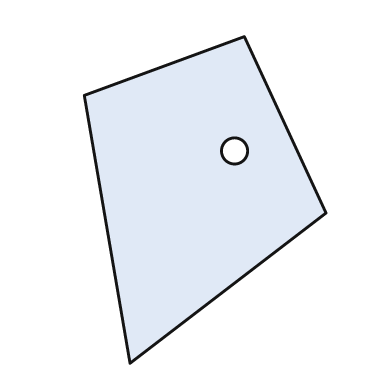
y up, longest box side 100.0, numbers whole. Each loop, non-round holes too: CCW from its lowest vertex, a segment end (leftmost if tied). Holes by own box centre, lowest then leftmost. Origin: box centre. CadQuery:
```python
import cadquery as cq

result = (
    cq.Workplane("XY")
    .moveTo(-23.0, -50.0)
    .lineTo(37.0, -4.0)
    .lineTo(12.0, 50.0)
    .lineTo(-37.0, 32.0)
    .close()
    .moveTo(9.0, 15.0)
    .circle(4.0)
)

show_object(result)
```